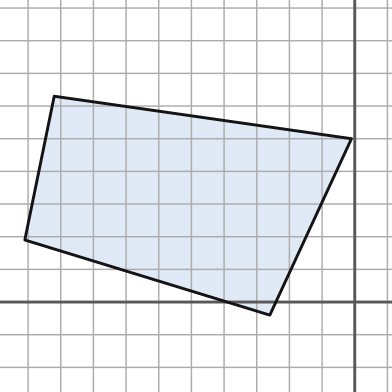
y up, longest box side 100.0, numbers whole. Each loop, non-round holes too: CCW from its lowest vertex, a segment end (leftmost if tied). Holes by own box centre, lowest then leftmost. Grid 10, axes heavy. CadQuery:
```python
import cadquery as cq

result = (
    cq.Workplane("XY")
    .moveTo(-26.0, -4.0)
    .lineTo(-1.0, 50.0)
    .lineTo(-92.0, 63.0)
    .lineTo(-101.0, 19.0)
    .close()
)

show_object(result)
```